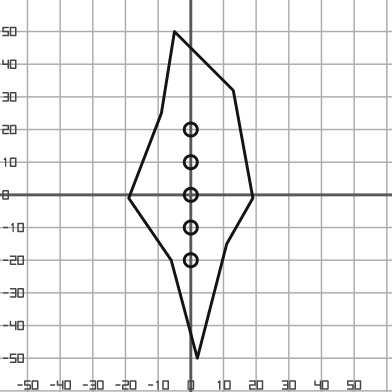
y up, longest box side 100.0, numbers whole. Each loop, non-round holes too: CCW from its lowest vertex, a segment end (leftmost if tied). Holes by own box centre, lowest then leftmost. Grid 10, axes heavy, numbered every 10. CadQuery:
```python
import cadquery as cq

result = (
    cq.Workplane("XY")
    .moveTo(2.0, -50.0)
    .lineTo(11.0, -15.0)
    .lineTo(19.0, -1.0)
    .lineTo(13.0, 32.0)
    .lineTo(-5.0, 50.0)
    .lineTo(-9.0, 25.0)
    .lineTo(-19.0, -1.0)
    .lineTo(-6.0, -20.0)
    .close()
    .moveTo(0.0, -20.0)
    .circle(2.0)
    .moveTo(0.0, -10.0)
    .circle(2.0)
    .moveTo(0.0, 0.0)
    .circle(2.0)
    .moveTo(0.0, 10.0)
    .circle(2.0)
    .moveTo(0.0, 20.0)
    .circle(2.0)
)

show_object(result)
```